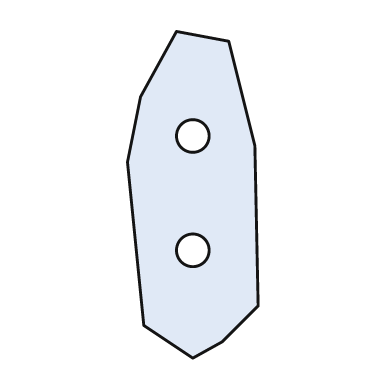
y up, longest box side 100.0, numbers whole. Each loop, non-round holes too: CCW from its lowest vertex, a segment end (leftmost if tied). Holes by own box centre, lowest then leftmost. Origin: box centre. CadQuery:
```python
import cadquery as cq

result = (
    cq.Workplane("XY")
    .moveTo(0.0, -50.0)
    .lineTo(9.0, -45.0)
    .lineTo(20.0, -34.0)
    .lineTo(19.0, 15.0)
    .lineTo(11.0, 47.0)
    .lineTo(-5.0, 50.0)
    .lineTo(-16.0, 30.0)
    .lineTo(-20.0, 10.0)
    .lineTo(-15.0, -40.0)
    .close()
    .moveTo(0.0, -17.0)
    .circle(5.0)
    .moveTo(0.0, 18.0)
    .circle(5.0)
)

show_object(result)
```